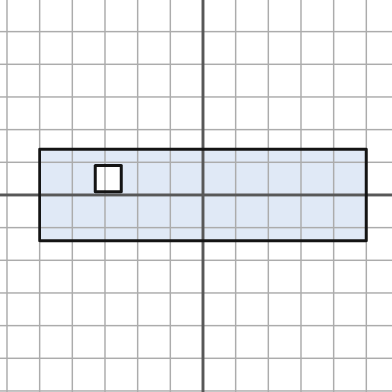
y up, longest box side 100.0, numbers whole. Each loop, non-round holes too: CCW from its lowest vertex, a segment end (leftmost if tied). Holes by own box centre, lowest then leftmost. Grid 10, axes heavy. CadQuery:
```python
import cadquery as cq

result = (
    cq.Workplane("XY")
    .moveTo(-50.0, -14.0)
    .lineTo(50.0, -14.0)
    .lineTo(50.0, 14.0)
    .lineTo(-50.0, 14.0)
    .close()
    .moveTo(-33.0, 1.0)
    .lineTo(-25.0, 1.0)
    .lineTo(-25.0, 9.0)
    .lineTo(-33.0, 9.0)
    .close()
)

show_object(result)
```